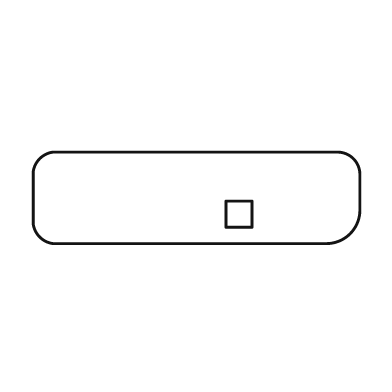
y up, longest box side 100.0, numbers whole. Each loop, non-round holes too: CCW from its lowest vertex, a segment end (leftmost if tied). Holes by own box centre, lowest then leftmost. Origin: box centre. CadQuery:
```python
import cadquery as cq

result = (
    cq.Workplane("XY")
    .moveTo(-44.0, -14.0)
    .lineTo(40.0, -14.0)
    .threePointArc((47.0, -11.0), (50.0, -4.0))
    .lineTo(50.0, 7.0)
    .threePointArc((48.0, 12.0), (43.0, 14.0))
    .lineTo(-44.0, 14.0)
    .threePointArc((-48.0, 12.0), (-50.0, 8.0))
    .lineTo(-50.0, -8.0)
    .threePointArc((-48.0, -12.0), (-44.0, -14.0))
    .close()
    .moveTo(9.0, -9.0)
    .lineTo(17.0, -9.0)
    .lineTo(17.0, -1.0)
    .lineTo(9.0, -1.0)
    .close()
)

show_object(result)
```